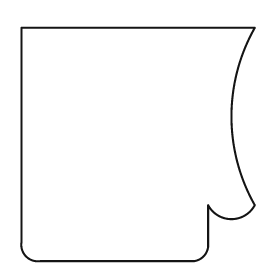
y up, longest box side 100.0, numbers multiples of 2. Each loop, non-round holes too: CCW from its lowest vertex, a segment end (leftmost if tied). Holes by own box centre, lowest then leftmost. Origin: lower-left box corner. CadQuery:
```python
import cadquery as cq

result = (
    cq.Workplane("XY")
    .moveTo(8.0, 0.0)
    .lineTo(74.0, 0.0)
    .threePointArc((78.0, 2.0), (80.0, 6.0))
    .lineTo(80.0, 24.0)
    .threePointArc((90.0, 18.0), (100.0, 24.0))
    .threePointArc((90.0, 62.0), (100.0, 100.0))
    .lineTo(0.0, 100.0)
    .lineTo(0.0, 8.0)
    .threePointArc((2.0, 2.0), (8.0, 0.0))
    .close()
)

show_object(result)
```